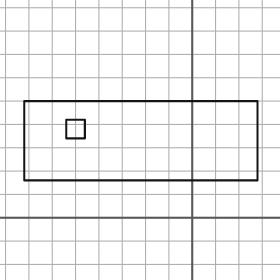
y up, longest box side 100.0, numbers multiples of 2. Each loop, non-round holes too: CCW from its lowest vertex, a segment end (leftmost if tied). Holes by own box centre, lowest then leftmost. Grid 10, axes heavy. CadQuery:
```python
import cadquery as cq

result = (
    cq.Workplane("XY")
    .moveTo(-72.0, 16.0)
    .lineTo(28.0, 16.0)
    .lineTo(28.0, 50.0)
    .lineTo(-72.0, 50.0)
    .close()
    .moveTo(-54.0, 34.0)
    .lineTo(-46.0, 34.0)
    .lineTo(-46.0, 42.0)
    .lineTo(-54.0, 42.0)
    .close()
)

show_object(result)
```